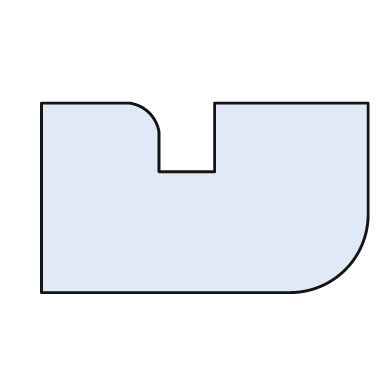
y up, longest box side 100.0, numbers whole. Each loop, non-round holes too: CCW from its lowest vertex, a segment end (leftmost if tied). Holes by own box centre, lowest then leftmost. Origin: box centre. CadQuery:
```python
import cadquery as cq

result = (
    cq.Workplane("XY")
    .moveTo(-50.0, -29.0)
    .lineTo(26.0, -29.0)
    .threePointArc((43.0, -22.0), (50.0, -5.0))
    .lineTo(50.0, 29.0)
    .lineTo(3.0, 29.0)
    .lineTo(3.0, 8.0)
    .lineTo(-14.0, 8.0)
    .lineTo(-14.0, 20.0)
    .threePointArc((-17.0, 26.0), (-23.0, 29.0))
    .lineTo(-50.0, 29.0)
    .close()
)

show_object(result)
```